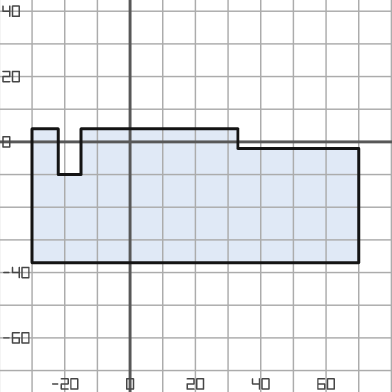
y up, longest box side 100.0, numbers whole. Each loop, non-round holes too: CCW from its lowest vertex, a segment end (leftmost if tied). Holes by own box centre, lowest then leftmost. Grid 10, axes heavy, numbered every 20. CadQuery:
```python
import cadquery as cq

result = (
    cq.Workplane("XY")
    .moveTo(-30.0, -37.0)
    .lineTo(70.0, -37.0)
    .lineTo(70.0, -2.0)
    .lineTo(33.0, -2.0)
    .lineTo(33.0, 4.0)
    .lineTo(-15.0, 4.0)
    .lineTo(-15.0, -10.0)
    .lineTo(-22.0, -10.0)
    .lineTo(-22.0, 4.0)
    .lineTo(-30.0, 4.0)
    .close()
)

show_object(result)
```